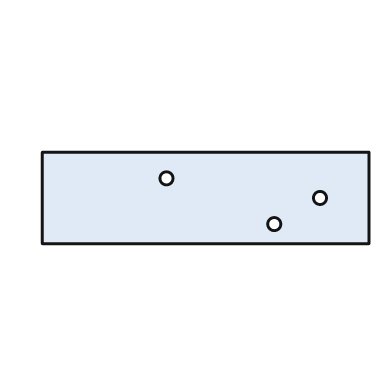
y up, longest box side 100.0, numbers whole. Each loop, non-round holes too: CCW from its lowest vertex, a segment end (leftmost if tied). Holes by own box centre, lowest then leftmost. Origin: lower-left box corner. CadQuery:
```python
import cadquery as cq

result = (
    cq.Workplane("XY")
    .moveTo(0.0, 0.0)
    .lineTo(100.0, 0.0)
    .lineTo(100.0, 28.0)
    .lineTo(0.0, 28.0)
    .close()
    .moveTo(71.0, 6.0)
    .circle(2.0)
    .moveTo(85.0, 14.0)
    .circle(2.0)
    .moveTo(38.0, 20.0)
    .circle(2.0)
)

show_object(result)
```